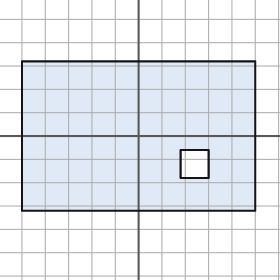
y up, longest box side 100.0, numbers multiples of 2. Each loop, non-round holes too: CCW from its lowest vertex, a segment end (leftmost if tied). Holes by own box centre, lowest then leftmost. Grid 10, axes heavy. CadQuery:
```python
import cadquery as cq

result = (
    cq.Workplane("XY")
    .moveTo(-50.0, -32.0)
    .lineTo(50.0, -32.0)
    .lineTo(50.0, 32.0)
    .lineTo(-50.0, 32.0)
    .close()
    .moveTo(18.0, -18.0)
    .lineTo(30.0, -18.0)
    .lineTo(30.0, -6.0)
    .lineTo(18.0, -6.0)
    .close()
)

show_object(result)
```